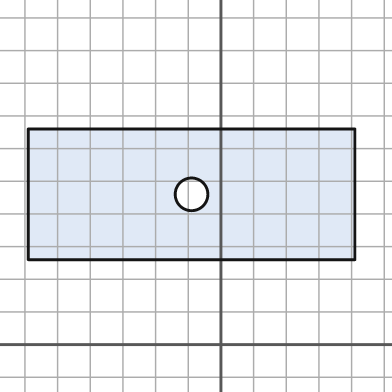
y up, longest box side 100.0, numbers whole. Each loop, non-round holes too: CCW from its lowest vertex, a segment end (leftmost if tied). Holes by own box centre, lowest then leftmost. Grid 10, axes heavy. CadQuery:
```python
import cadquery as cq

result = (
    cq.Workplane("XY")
    .moveTo(-59.0, 26.0)
    .lineTo(41.0, 26.0)
    .lineTo(41.0, 66.0)
    .lineTo(-59.0, 66.0)
    .close()
    .moveTo(-9.0, 46.0)
    .circle(5.0)
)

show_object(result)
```